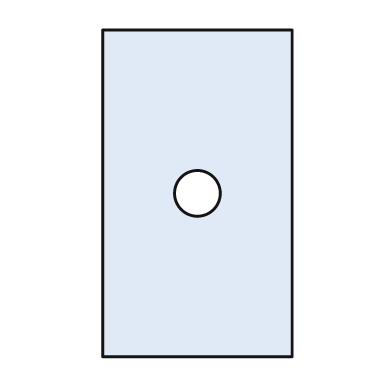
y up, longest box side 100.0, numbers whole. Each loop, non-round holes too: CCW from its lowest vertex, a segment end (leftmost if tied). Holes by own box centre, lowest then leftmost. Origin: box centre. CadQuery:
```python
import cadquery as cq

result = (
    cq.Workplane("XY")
    .moveTo(-29.0, -50.0)
    .lineTo(29.0, -50.0)
    .lineTo(29.0, 50.0)
    .lineTo(-29.0, 50.0)
    .close()
    .moveTo(0.0, 0.0)
    .circle(7.0)
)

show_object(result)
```